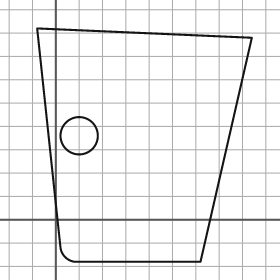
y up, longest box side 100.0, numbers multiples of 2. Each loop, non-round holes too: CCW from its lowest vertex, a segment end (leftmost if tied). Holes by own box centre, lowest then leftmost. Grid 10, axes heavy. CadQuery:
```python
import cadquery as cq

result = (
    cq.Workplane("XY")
    .moveTo(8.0, -18.0)
    .lineTo(62.0, -18.0)
    .lineTo(84.0, 78.0)
    .lineTo(-8.0, 82.0)
    .lineTo(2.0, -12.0)
    .threePointArc((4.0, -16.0), (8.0, -18.0))
    .close()
    .moveTo(10.0, 36.0)
    .circle(8.0)
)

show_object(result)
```